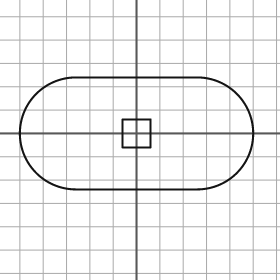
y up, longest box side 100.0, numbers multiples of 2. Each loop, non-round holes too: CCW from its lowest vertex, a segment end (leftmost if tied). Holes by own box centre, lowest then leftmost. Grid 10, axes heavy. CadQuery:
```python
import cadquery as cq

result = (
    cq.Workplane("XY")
    .moveTo(-26.0, -24.0)
    .lineTo(26.0, -24.0)
    .threePointArc((50.0, 0.0), (26.0, 24.0))
    .lineTo(-26.0, 24.0)
    .threePointArc((-50.0, 0.0), (-26.0, -24.0))
    .close()
    .moveTo(-6.0, -6.0)
    .lineTo(6.0, -6.0)
    .lineTo(6.0, 6.0)
    .lineTo(-6.0, 6.0)
    .close()
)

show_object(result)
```